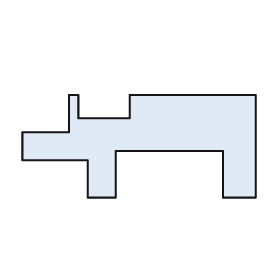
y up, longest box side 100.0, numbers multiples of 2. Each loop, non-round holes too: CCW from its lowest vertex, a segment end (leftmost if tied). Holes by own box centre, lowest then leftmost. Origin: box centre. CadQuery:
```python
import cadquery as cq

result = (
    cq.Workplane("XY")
    .moveTo(-22.0, -22.0)
    .lineTo(-10.0, -22.0)
    .lineTo(-10.0, -2.0)
    .lineTo(36.0, -2.0)
    .lineTo(36.0, -22.0)
    .lineTo(50.0, -22.0)
    .lineTo(50.0, 22.0)
    .lineTo(-4.0, 22.0)
    .lineTo(-4.0, 12.0)
    .lineTo(-26.0, 12.0)
    .lineTo(-26.0, 22.0)
    .lineTo(-30.0, 22.0)
    .lineTo(-30.0, 6.0)
    .lineTo(-50.0, 6.0)
    .lineTo(-50.0, -6.0)
    .lineTo(-22.0, -6.0)
    .close()
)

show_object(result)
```